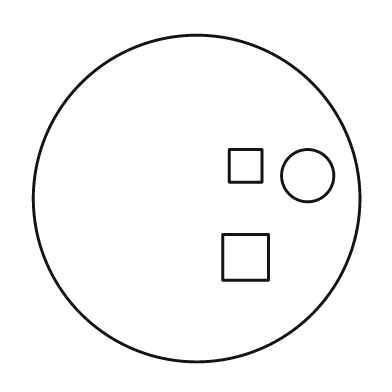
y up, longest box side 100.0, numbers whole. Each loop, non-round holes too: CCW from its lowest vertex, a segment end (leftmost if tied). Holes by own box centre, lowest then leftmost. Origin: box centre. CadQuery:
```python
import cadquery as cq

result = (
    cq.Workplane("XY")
    .moveTo(0.0, 0.0)
    .circle(50.0)
    .moveTo(8.0, -25.0)
    .lineTo(22.0, -25.0)
    .lineTo(22.0, -11.0)
    .lineTo(8.0, -11.0)
    .close()
    .moveTo(34.0, 7.0)
    .circle(8.0)
    .moveTo(10.0, 5.0)
    .lineTo(20.0, 5.0)
    .lineTo(20.0, 15.0)
    .lineTo(10.0, 15.0)
    .close()
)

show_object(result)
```